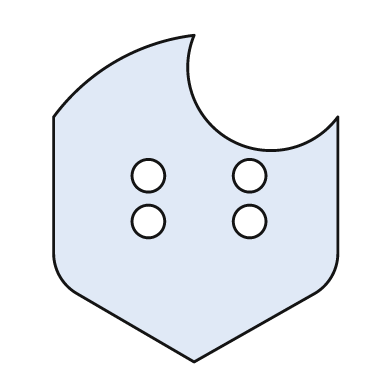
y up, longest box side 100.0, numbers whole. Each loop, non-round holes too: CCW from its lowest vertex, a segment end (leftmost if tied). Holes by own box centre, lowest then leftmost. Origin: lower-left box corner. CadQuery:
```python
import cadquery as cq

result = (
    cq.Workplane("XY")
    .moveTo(43.0, 0.0)
    .lineTo(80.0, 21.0)
    .threePointArc((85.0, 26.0), (87.0, 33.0))
    .lineTo(87.0, 75.0)
    .threePointArc((54.0, 68.0), (43.0, 100.0))
    .threePointArc((19.0, 92.0), (0.0, 75.0))
    .lineTo(0.0, 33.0)
    .threePointArc((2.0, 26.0), (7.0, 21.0))
    .close()
    .moveTo(29.0, 43.0)
    .circle(5.0)
    .moveTo(60.0, 43.0)
    .circle(5.0)
    .moveTo(29.0, 57.0)
    .circle(5.0)
    .moveTo(60.0, 57.0)
    .circle(5.0)
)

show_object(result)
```